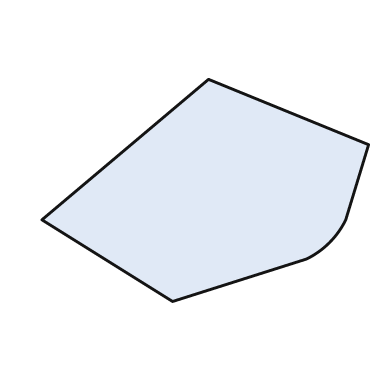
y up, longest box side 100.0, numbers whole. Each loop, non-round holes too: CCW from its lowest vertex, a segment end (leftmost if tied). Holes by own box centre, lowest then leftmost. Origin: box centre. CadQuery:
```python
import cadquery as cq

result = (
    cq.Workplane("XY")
    .moveTo(-10.0, -34.0)
    .lineTo(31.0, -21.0)
    .threePointArc((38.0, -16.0), (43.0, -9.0))
    .lineTo(50.0, 14.0)
    .lineTo(1.0, 34.0)
    .lineTo(-50.0, -9.0)
    .close()
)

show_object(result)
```